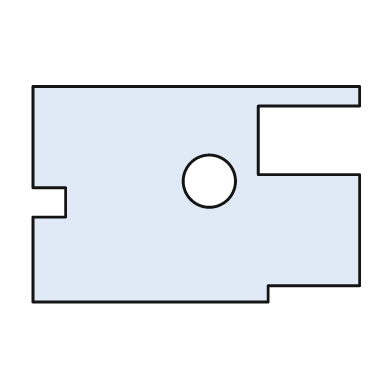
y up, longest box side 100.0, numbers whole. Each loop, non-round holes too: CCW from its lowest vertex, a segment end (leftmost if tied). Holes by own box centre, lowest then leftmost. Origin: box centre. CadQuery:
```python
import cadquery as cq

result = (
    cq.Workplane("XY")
    .moveTo(-50.0, -33.0)
    .lineTo(22.0, -33.0)
    .lineTo(22.0, -28.0)
    .lineTo(50.0, -28.0)
    .lineTo(50.0, 6.0)
    .lineTo(19.0, 6.0)
    .lineTo(19.0, 27.0)
    .lineTo(50.0, 27.0)
    .lineTo(50.0, 33.0)
    .lineTo(-50.0, 33.0)
    .lineTo(-50.0, 2.0)
    .lineTo(-40.0, 2.0)
    .lineTo(-40.0, -7.0)
    .lineTo(-50.0, -7.0)
    .close()
    .moveTo(4.0, 4.0)
    .circle(8.0)
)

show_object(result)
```